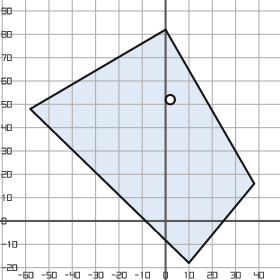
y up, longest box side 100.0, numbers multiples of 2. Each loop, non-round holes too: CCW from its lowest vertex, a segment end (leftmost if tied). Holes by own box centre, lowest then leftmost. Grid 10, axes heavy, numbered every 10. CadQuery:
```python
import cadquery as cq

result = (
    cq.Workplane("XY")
    .moveTo(10.0, -18.0)
    .lineTo(38.0, 16.0)
    .lineTo(0.0, 82.0)
    .lineTo(-58.0, 48.0)
    .close()
    .moveTo(2.0, 52.0)
    .circle(2.0)
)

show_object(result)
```